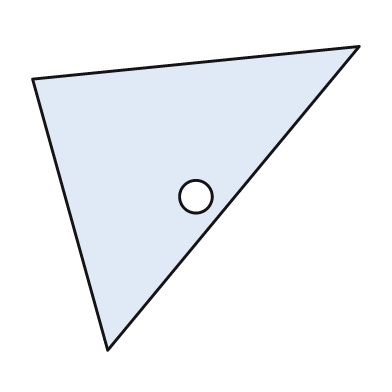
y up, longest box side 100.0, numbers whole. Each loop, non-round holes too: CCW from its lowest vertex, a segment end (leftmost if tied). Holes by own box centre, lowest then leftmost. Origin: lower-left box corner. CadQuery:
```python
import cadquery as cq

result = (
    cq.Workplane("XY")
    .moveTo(23.0, 0.0)
    .lineTo(100.0, 93.0)
    .lineTo(0.0, 83.0)
    .close()
    .moveTo(50.0, 47.0)
    .circle(5.0)
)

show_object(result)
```